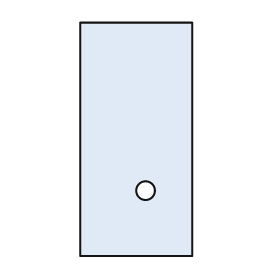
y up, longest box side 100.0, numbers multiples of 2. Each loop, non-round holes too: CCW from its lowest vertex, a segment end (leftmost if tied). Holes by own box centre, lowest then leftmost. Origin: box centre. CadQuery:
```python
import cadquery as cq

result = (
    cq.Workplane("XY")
    .moveTo(-24.0, -50.0)
    .lineTo(24.0, -50.0)
    .lineTo(24.0, 50.0)
    .lineTo(-24.0, 50.0)
    .close()
    .moveTo(4.0, -22.0)
    .circle(4.0)
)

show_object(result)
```